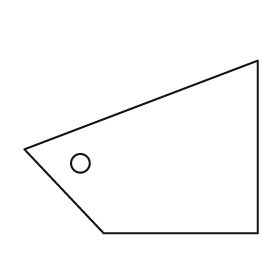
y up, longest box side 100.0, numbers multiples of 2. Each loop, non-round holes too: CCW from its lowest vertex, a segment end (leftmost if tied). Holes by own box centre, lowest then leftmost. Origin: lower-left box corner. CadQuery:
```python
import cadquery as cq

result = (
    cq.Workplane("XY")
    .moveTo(34.0, 0.0)
    .lineTo(100.0, 0.0)
    .lineTo(100.0, 74.0)
    .lineTo(0.0, 36.0)
    .close()
    .moveTo(24.0, 30.0)
    .circle(4.0)
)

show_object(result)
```